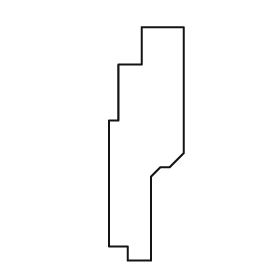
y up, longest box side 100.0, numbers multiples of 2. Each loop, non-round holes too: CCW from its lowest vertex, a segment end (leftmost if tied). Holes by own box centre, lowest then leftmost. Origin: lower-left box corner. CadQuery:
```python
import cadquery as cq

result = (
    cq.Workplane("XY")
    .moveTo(8.0, 0.0)
    .lineTo(18.0, 0.0)
    .lineTo(18.0, 36.0)
    .lineTo(22.0, 40.0)
    .lineTo(26.0, 40.0)
    .lineTo(32.0, 46.0)
    .lineTo(32.0, 100.0)
    .lineTo(14.0, 100.0)
    .lineTo(14.0, 84.0)
    .lineTo(4.0, 84.0)
    .lineTo(4.0, 60.0)
    .lineTo(0.0, 60.0)
    .lineTo(0.0, 6.0)
    .lineTo(8.0, 6.0)
    .close()
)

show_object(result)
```